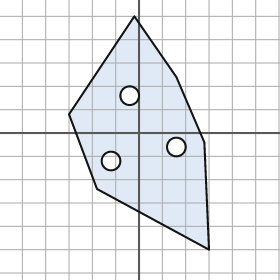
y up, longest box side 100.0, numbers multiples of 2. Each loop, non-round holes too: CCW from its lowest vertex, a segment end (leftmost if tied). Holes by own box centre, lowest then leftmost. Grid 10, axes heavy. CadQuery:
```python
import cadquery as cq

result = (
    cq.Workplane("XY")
    .moveTo(30.0, -50.0)
    .lineTo(28.0, -4.0)
    .lineTo(16.0, 24.0)
    .lineTo(-2.0, 50.0)
    .lineTo(-30.0, 8.0)
    .lineTo(-18.0, -24.0)
    .close()
    .moveTo(-12.0, -12.0)
    .circle(4.0)
    .moveTo(16.0, -6.0)
    .circle(4.0)
    .moveTo(-4.0, 16.0)
    .circle(4.0)
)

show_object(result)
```